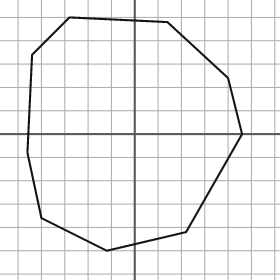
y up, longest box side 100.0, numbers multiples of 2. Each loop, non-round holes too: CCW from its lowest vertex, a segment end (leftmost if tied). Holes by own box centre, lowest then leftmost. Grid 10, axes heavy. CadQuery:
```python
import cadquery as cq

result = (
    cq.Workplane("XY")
    .moveTo(-12.0, -50.0)
    .lineTo(22.0, -42.0)
    .lineTo(46.0, 0.0)
    .lineTo(40.0, 24.0)
    .lineTo(14.0, 48.0)
    .lineTo(-28.0, 50.0)
    .lineTo(-44.0, 34.0)
    .lineTo(-46.0, -8.0)
    .lineTo(-40.0, -36.0)
    .close()
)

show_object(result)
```